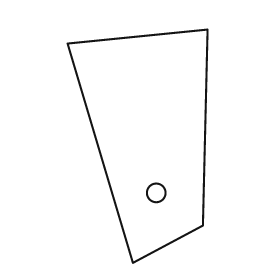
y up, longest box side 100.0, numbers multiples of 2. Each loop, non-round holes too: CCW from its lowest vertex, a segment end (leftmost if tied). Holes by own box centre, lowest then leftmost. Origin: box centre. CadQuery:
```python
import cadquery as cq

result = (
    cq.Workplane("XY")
    .moveTo(-2.0, -50.0)
    .lineTo(28.0, -34.0)
    .lineTo(30.0, 50.0)
    .lineTo(-30.0, 44.0)
    .close()
    .moveTo(8.0, -20.0)
    .circle(4.0)
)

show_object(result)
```